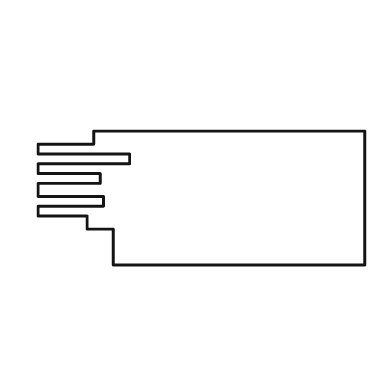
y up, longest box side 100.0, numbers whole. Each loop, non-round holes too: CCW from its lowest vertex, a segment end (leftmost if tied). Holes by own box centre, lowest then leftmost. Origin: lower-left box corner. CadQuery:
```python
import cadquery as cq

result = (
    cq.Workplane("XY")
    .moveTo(23.0, 0.0)
    .lineTo(100.0, 0.0)
    .lineTo(100.0, 41.0)
    .lineTo(17.0, 41.0)
    .lineTo(17.0, 37.0)
    .lineTo(0.0, 37.0)
    .lineTo(0.0, 34.0)
    .lineTo(28.0, 34.0)
    .lineTo(28.0, 31.0)
    .lineTo(0.0, 31.0)
    .lineTo(0.0, 28.0)
    .lineTo(19.0, 28.0)
    .lineTo(19.0, 25.0)
    .lineTo(0.0, 25.0)
    .lineTo(0.0, 21.0)
    .lineTo(20.0, 21.0)
    .lineTo(20.0, 18.0)
    .lineTo(0.0, 18.0)
    .lineTo(0.0, 15.0)
    .lineTo(15.0, 15.0)
    .lineTo(15.0, 11.0)
    .lineTo(23.0, 11.0)
    .close()
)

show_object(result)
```